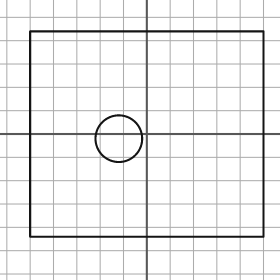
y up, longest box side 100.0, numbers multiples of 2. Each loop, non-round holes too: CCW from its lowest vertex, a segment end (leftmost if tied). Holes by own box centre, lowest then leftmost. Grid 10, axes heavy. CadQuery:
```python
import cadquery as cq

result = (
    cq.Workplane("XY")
    .moveTo(-50.0, -44.0)
    .lineTo(50.0, -44.0)
    .lineTo(50.0, 44.0)
    .lineTo(-50.0, 44.0)
    .close()
    .moveTo(-12.0, -2.0)
    .circle(10.0)
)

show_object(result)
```